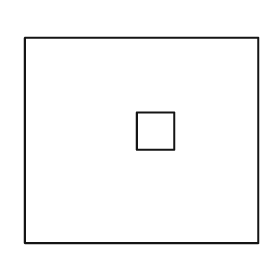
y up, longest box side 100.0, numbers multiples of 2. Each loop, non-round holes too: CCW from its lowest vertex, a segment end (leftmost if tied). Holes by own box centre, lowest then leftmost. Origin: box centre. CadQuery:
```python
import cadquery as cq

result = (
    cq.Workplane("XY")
    .moveTo(-50.0, -44.0)
    .lineTo(50.0, -44.0)
    .lineTo(50.0, 44.0)
    .lineTo(-50.0, 44.0)
    .close()
    .moveTo(-2.0, -4.0)
    .lineTo(14.0, -4.0)
    .lineTo(14.0, 12.0)
    .lineTo(-2.0, 12.0)
    .close()
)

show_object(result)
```